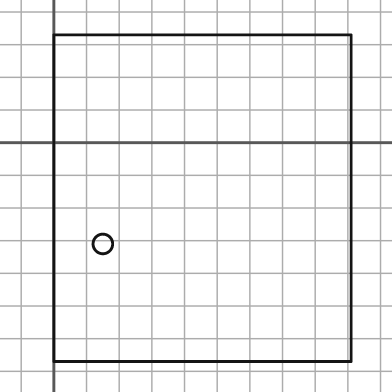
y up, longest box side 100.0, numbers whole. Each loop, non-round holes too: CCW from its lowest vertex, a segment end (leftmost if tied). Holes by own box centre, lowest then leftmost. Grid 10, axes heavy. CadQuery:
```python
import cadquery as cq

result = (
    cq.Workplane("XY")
    .moveTo(0.0, -67.0)
    .lineTo(91.0, -67.0)
    .lineTo(91.0, 33.0)
    .lineTo(0.0, 33.0)
    .close()
    .moveTo(15.0, -31.0)
    .circle(3.0)
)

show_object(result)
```